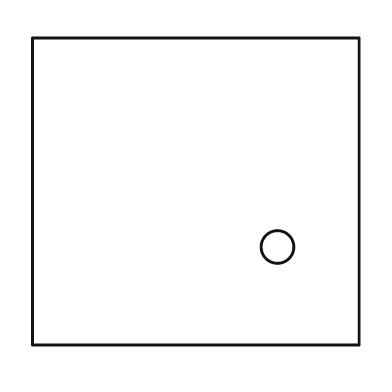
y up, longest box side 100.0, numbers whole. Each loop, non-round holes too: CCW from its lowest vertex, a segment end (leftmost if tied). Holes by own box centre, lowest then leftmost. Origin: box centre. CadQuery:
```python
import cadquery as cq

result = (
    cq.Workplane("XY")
    .moveTo(-50.0, -47.0)
    .lineTo(50.0, -47.0)
    .lineTo(50.0, 47.0)
    .lineTo(-50.0, 47.0)
    .close()
    .moveTo(25.0, -17.0)
    .circle(5.0)
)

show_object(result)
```